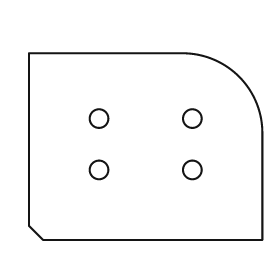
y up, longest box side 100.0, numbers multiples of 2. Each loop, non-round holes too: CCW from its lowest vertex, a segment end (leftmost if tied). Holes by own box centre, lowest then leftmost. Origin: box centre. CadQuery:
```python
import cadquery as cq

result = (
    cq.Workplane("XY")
    .moveTo(-44.0, -40.0)
    .lineTo(50.0, -40.0)
    .lineTo(50.0, 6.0)
    .threePointArc((40.0, 30.0), (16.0, 40.0))
    .lineTo(-50.0, 40.0)
    .lineTo(-50.0, -34.0)
    .close()
    .moveTo(-20.0, -10.0)
    .circle(4.0)
    .moveTo(20.0, -10.0)
    .circle(4.0)
    .moveTo(-20.0, 12.0)
    .circle(4.0)
    .moveTo(20.0, 12.0)
    .circle(4.0)
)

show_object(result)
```